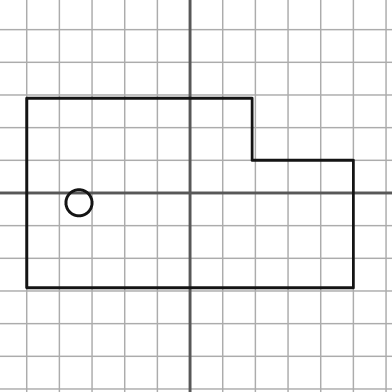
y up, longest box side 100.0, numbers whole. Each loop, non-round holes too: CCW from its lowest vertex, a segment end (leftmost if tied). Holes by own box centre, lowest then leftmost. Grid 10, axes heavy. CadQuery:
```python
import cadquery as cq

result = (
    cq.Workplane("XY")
    .moveTo(-50.0, -29.0)
    .lineTo(50.0, -29.0)
    .lineTo(50.0, 10.0)
    .lineTo(19.0, 10.0)
    .lineTo(19.0, 29.0)
    .lineTo(-50.0, 29.0)
    .close()
    .moveTo(-34.0, -3.0)
    .circle(4.0)
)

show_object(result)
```